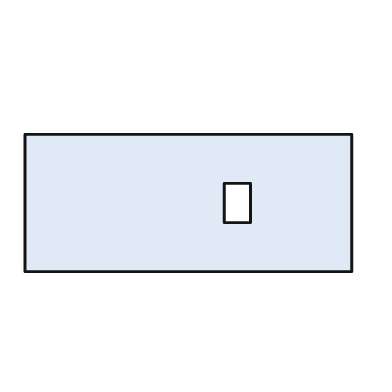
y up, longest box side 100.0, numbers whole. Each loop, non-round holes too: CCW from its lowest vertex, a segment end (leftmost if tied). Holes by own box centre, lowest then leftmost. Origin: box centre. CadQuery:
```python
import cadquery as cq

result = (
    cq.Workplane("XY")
    .moveTo(-50.0, -21.0)
    .lineTo(50.0, -21.0)
    .lineTo(50.0, 21.0)
    .lineTo(-50.0, 21.0)
    .close()
    .moveTo(11.0, -6.0)
    .lineTo(19.0, -6.0)
    .lineTo(19.0, 6.0)
    .lineTo(11.0, 6.0)
    .close()
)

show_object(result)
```